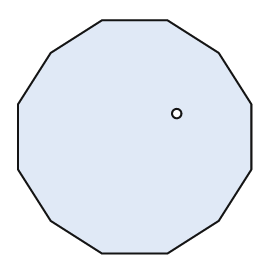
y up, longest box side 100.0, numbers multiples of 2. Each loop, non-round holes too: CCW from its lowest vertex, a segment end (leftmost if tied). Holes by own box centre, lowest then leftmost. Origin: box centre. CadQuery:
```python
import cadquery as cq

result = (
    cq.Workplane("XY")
    .moveTo(-14.0, -50.0)
    .lineTo(14.0, -50.0)
    .lineTo(36.0, -36.0)
    .lineTo(50.0, -14.0)
    .lineTo(50.0, 14.0)
    .lineTo(36.0, 36.0)
    .lineTo(14.0, 50.0)
    .lineTo(-14.0, 50.0)
    .lineTo(-36.0, 36.0)
    .lineTo(-50.0, 14.0)
    .lineTo(-50.0, -14.0)
    .lineTo(-36.0, -36.0)
    .close()
    .moveTo(18.0, 10.0)
    .circle(2.0)
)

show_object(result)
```